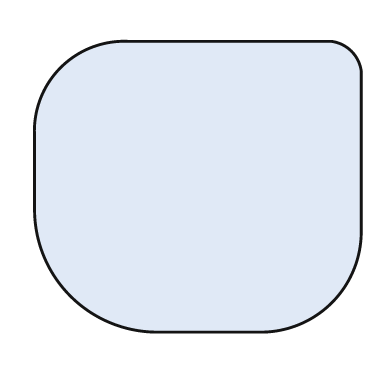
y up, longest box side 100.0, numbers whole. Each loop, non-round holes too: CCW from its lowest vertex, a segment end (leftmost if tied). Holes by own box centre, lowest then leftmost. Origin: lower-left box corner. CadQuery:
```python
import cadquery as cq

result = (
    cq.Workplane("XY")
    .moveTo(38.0, 0.0)
    .lineTo(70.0, 0.0)
    .threePointArc((91.0, 9.0), (100.0, 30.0))
    .lineTo(100.0, 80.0)
    .threePointArc((97.0, 86.0), (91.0, 89.0))
    .lineTo(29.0, 89.0)
    .threePointArc((8.0, 81.0), (0.0, 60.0))
    .lineTo(0.0, 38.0)
    .threePointArc((11.0, 11.0), (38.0, 0.0))
    .close()
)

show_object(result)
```